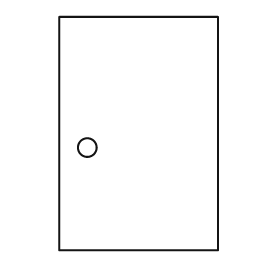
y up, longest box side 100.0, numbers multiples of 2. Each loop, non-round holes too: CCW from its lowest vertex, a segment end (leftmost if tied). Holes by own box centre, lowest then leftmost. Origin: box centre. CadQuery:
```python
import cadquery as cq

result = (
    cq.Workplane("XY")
    .moveTo(-34.0, -50.0)
    .lineTo(34.0, -50.0)
    .lineTo(34.0, 50.0)
    .lineTo(-34.0, 50.0)
    .close()
    .moveTo(-22.0, -6.0)
    .circle(4.0)
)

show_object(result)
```